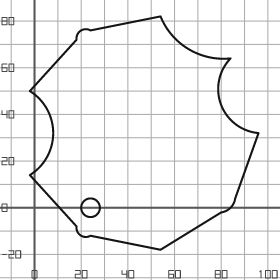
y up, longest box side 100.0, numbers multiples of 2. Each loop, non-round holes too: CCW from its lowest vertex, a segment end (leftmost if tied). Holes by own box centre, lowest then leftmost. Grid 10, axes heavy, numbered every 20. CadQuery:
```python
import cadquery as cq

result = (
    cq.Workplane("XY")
    .moveTo(54.0, -18.0)
    .lineTo(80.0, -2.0)
    .threePointArc((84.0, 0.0), (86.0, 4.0))
    .lineTo(96.0, 32.0)
    .threePointArc((80.0, 44.0), (84.0, 64.0))
    .threePointArc((66.0, 68.0), (54.0, 82.0))
    .lineTo(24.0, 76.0)
    .threePointArc((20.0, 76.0), (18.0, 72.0))
    .lineTo(-2.0, 50.0)
    .threePointArc((8.0, 32.0), (-2.0, 14.0))
    .lineTo(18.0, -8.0)
    .threePointArc((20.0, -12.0), (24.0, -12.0))
    .close()
    .moveTo(24.0, 0.0)
    .circle(4.0)
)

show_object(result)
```